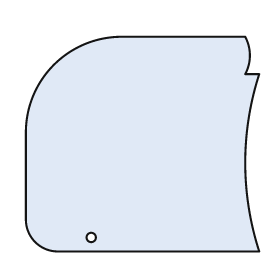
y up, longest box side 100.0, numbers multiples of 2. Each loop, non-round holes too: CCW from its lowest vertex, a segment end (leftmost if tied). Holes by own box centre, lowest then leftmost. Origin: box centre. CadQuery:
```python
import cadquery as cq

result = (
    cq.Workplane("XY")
    .moveTo(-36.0, -46.0)
    .lineTo(50.0, -46.0)
    .threePointArc((44.0, -8.0), (50.0, 30.0))
    .lineTo(44.0, 30.0)
    .threePointArc((46.0, 38.0), (44.0, 46.0))
    .lineTo(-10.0, 46.0)
    .threePointArc((-38.0, 34.0), (-50.0, 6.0))
    .lineTo(-50.0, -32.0)
    .threePointArc((-46.0, -42.0), (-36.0, -46.0))
    .close()
    .moveTo(-22.0, -40.0)
    .circle(2.0)
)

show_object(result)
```